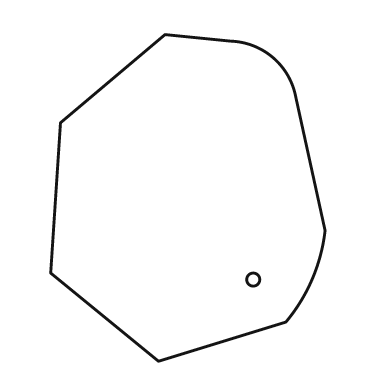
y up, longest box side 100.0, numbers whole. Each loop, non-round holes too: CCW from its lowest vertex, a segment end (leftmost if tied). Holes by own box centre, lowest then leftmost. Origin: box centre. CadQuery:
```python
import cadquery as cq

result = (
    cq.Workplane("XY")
    .moveTo(-9.0, -50.0)
    .lineTo(30.0, -38.0)
    .threePointArc((38.0, -25.0), (42.0, -10.0))
    .lineTo(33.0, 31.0)
    .threePointArc((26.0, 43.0), (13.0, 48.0))
    .lineTo(-7.0, 50.0)
    .lineTo(-39.0, 23.0)
    .lineTo(-42.0, -23.0)
    .close()
    .moveTo(20.0, -25.0)
    .circle(2.0)
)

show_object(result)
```